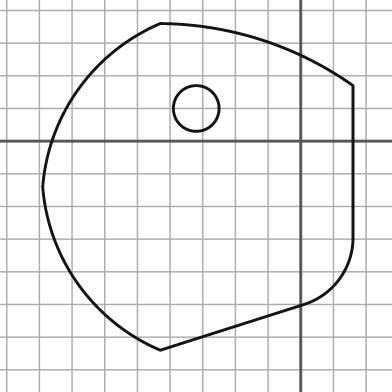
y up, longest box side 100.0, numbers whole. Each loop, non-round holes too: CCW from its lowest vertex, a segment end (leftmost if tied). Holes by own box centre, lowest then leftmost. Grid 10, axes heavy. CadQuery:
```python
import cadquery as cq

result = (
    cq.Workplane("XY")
    .moveTo(-43.0, -64.0)
    .lineTo(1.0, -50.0)
    .threePointArc((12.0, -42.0), (16.0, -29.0))
    .lineTo(16.0, 17.0)
    .threePointArc((-12.0, 31.0), (-43.0, 36.0))
    .threePointArc((-68.0, 16.0), (-79.0, -14.0))
    .threePointArc((-68.0, -44.0), (-43.0, -64.0))
    .close()
    .moveTo(-32.0, 10.0)
    .circle(7.0)
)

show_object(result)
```